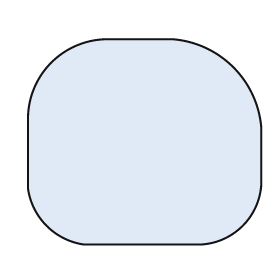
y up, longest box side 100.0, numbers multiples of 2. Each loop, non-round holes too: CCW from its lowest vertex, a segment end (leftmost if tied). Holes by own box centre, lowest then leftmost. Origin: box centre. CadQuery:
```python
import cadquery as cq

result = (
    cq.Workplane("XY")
    .moveTo(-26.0, -44.0)
    .lineTo(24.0, -44.0)
    .threePointArc((42.0, -36.0), (50.0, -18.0))
    .lineTo(50.0, 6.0)
    .threePointArc((38.0, 32.0), (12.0, 44.0))
    .lineTo(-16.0, 44.0)
    .threePointArc((-40.0, 34.0), (-50.0, 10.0))
    .lineTo(-50.0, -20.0)
    .threePointArc((-42.0, -36.0), (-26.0, -44.0))
    .close()
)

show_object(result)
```